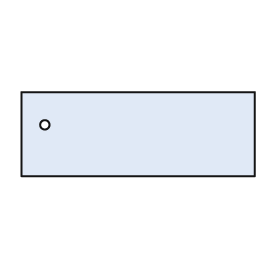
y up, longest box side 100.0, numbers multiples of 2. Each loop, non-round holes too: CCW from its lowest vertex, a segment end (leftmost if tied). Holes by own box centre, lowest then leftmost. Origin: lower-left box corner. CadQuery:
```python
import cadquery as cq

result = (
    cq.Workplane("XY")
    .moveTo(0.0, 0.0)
    .lineTo(100.0, 0.0)
    .lineTo(100.0, 36.0)
    .lineTo(0.0, 36.0)
    .close()
    .moveTo(10.0, 22.0)
    .circle(2.0)
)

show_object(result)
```